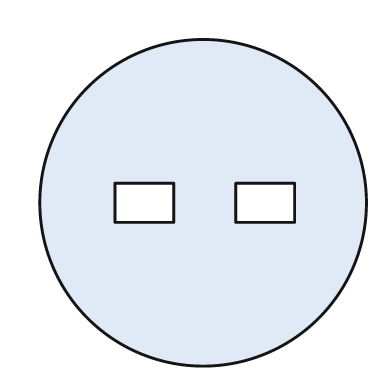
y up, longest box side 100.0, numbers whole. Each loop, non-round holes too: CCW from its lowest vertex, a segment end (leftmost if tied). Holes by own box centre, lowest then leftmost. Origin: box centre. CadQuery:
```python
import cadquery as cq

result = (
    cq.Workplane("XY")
    .moveTo(0.0, 0.0)
    .circle(50.0)
    .moveTo(-27.0, -6.0)
    .lineTo(-9.0, -6.0)
    .lineTo(-9.0, 6.0)
    .lineTo(-27.0, 6.0)
    .close()
    .moveTo(10.0, -6.0)
    .lineTo(28.0, -6.0)
    .lineTo(28.0, 6.0)
    .lineTo(10.0, 6.0)
    .close()
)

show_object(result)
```